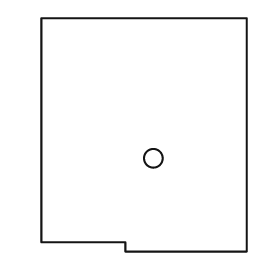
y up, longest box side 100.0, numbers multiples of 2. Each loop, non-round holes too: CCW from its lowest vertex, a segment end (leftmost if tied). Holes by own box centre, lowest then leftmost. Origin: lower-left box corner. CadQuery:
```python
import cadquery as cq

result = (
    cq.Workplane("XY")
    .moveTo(36.0, 0.0)
    .lineTo(88.0, 0.0)
    .lineTo(88.0, 100.0)
    .lineTo(0.0, 100.0)
    .lineTo(0.0, 4.0)
    .lineTo(36.0, 4.0)
    .close()
    .moveTo(48.0, 40.0)
    .circle(4.0)
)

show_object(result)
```